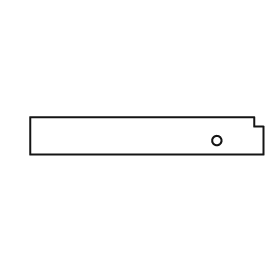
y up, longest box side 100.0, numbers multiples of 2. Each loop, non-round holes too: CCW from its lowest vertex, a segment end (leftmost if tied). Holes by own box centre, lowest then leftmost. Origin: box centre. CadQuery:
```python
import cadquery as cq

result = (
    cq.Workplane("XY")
    .moveTo(-50.0, -8.0)
    .lineTo(50.0, -8.0)
    .lineTo(50.0, 4.0)
    .lineTo(46.0, 4.0)
    .lineTo(46.0, 8.0)
    .lineTo(-50.0, 8.0)
    .close()
    .moveTo(30.0, -2.0)
    .circle(2.0)
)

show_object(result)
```